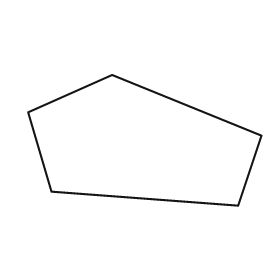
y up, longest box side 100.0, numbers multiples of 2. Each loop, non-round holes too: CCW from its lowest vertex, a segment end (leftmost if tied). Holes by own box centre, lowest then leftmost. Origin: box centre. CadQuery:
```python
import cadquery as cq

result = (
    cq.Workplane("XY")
    .moveTo(40.0, -28.0)
    .lineTo(50.0, 2.0)
    .lineTo(-14.0, 28.0)
    .lineTo(-50.0, 12.0)
    .lineTo(-40.0, -22.0)
    .close()
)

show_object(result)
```